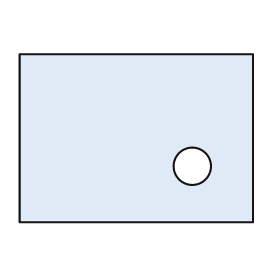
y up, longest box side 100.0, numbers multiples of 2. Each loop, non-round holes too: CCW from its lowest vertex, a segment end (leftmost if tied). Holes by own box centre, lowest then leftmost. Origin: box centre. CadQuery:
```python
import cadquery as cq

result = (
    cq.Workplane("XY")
    .moveTo(-50.0, -36.0)
    .lineTo(50.0, -36.0)
    .lineTo(50.0, 36.0)
    .lineTo(-50.0, 36.0)
    .close()
    .moveTo(24.0, -12.0)
    .circle(8.0)
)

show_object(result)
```